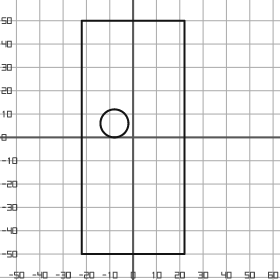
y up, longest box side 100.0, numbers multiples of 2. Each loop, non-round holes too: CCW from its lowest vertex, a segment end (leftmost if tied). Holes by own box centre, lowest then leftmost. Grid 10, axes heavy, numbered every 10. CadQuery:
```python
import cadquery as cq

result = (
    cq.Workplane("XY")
    .moveTo(-22.0, -50.0)
    .lineTo(22.0, -50.0)
    .lineTo(22.0, 50.0)
    .lineTo(-22.0, 50.0)
    .close()
    .moveTo(-8.0, 6.0)
    .circle(6.0)
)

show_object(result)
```